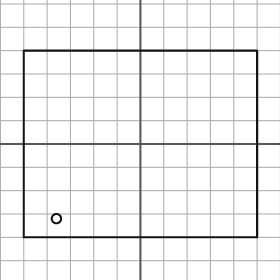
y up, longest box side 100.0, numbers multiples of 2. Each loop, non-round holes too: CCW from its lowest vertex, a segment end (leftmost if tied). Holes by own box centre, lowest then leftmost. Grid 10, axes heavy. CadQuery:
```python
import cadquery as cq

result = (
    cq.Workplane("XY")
    .moveTo(-50.0, -40.0)
    .lineTo(50.0, -40.0)
    .lineTo(50.0, 40.0)
    .lineTo(-50.0, 40.0)
    .close()
    .moveTo(-36.0, -32.0)
    .circle(2.0)
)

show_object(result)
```